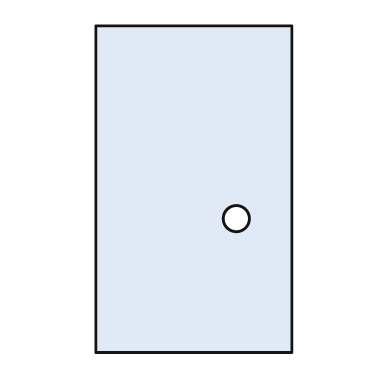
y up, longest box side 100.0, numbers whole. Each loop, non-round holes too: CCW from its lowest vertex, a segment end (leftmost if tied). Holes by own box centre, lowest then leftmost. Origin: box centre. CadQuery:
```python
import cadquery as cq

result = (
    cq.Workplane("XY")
    .moveTo(-30.0, -50.0)
    .lineTo(30.0, -50.0)
    .lineTo(30.0, 50.0)
    .lineTo(-30.0, 50.0)
    .close()
    .moveTo(13.0, -9.0)
    .circle(4.0)
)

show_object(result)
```